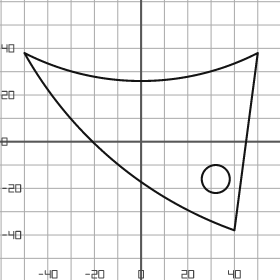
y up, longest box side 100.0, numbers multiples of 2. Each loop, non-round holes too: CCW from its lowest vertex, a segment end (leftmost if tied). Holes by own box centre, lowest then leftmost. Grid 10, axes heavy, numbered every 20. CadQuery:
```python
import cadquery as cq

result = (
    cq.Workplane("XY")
    .moveTo(40.0, -38.0)
    .lineTo(50.0, 38.0)
    .threePointArc((0.0, 26.0), (-50.0, 38.0))
    .threePointArc((-12.0, -8.0), (40.0, -38.0))
    .close()
    .moveTo(32.0, -16.0)
    .circle(6.0)
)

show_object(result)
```